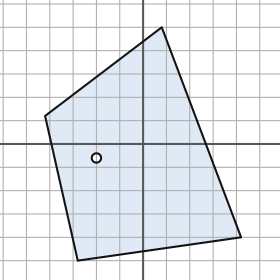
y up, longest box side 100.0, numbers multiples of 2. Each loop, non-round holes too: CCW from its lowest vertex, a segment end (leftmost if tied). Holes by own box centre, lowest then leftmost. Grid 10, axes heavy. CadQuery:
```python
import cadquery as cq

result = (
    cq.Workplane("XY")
    .moveTo(-28.0, -50.0)
    .lineTo(42.0, -40.0)
    .lineTo(8.0, 50.0)
    .lineTo(-42.0, 12.0)
    .close()
    .moveTo(-20.0, -6.0)
    .circle(2.0)
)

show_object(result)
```